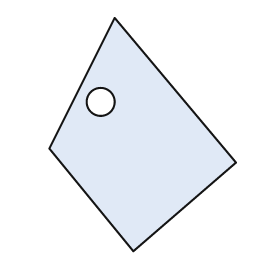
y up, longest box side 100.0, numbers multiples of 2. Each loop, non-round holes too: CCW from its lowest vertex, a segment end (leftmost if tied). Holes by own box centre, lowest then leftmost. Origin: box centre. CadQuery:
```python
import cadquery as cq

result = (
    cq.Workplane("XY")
    .moveTo(-4.0, -50.0)
    .lineTo(40.0, -12.0)
    .lineTo(-12.0, 50.0)
    .lineTo(-40.0, -6.0)
    .close()
    .moveTo(-18.0, 14.0)
    .circle(6.0)
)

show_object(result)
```